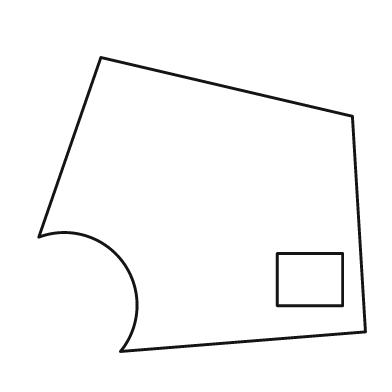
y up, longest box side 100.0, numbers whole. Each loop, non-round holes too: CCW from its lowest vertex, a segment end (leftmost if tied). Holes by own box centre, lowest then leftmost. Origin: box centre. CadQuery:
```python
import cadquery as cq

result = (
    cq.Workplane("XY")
    .moveTo(-25.0, -45.0)
    .lineTo(50.0, -39.0)
    .lineTo(46.0, 27.0)
    .lineTo(-31.0, 45.0)
    .lineTo(-50.0, -10.0)
    .threePointArc((-24.0, -18.0), (-25.0, -45.0))
    .close()
    .moveTo(23.0, -31.0)
    .lineTo(43.0, -31.0)
    .lineTo(43.0, -15.0)
    .lineTo(23.0, -15.0)
    .close()
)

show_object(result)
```